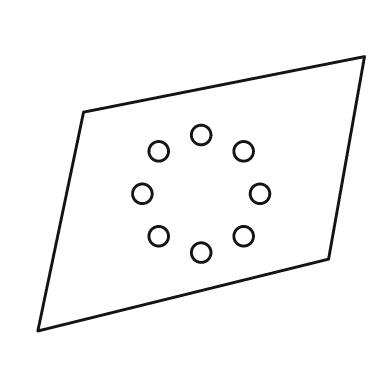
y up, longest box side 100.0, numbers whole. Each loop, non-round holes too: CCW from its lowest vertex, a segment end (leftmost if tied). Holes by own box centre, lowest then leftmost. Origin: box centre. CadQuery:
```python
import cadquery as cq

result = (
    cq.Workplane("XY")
    .moveTo(-50.0, -42.0)
    .lineTo(39.0, -20.0)
    .lineTo(50.0, 42.0)
    .lineTo(-36.0, 25.0)
    .close()
    .moveTo(0.0, -18.0)
    .circle(3.0)
    .moveTo(-13.0, -13.0)
    .circle(3.0)
    .moveTo(13.0, -13.0)
    .circle(3.0)
    .moveTo(-18.0, 0.0)
    .circle(3.0)
    .moveTo(18.0, 0.0)
    .circle(3.0)
    .moveTo(-13.0, 13.0)
    .circle(3.0)
    .moveTo(13.0, 13.0)
    .circle(3.0)
    .moveTo(0.0, 18.0)
    .circle(3.0)
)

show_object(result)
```